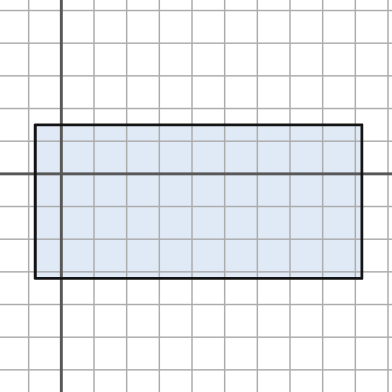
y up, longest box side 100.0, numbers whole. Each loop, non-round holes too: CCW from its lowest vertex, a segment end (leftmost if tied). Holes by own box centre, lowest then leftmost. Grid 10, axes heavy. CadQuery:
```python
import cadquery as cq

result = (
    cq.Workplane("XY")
    .moveTo(-8.0, -32.0)
    .lineTo(92.0, -32.0)
    .lineTo(92.0, 15.0)
    .lineTo(-8.0, 15.0)
    .close()
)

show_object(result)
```